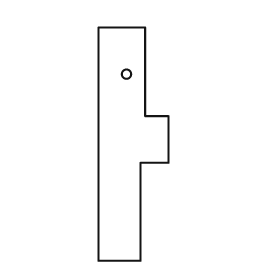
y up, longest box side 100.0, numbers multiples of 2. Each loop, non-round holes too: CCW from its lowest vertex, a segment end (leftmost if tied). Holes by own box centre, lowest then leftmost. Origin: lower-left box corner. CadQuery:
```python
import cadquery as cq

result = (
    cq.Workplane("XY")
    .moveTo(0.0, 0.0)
    .lineTo(18.0, 0.0)
    .lineTo(18.0, 42.0)
    .lineTo(30.0, 42.0)
    .lineTo(30.0, 62.0)
    .lineTo(20.0, 62.0)
    .lineTo(20.0, 100.0)
    .lineTo(0.0, 100.0)
    .close()
    .moveTo(12.0, 80.0)
    .circle(2.0)
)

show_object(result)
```